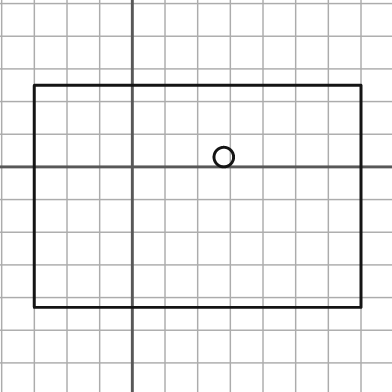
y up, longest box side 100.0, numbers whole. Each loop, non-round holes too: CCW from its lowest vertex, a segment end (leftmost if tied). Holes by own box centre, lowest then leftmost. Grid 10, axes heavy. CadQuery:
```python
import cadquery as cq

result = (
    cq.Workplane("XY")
    .moveTo(-30.0, -43.0)
    .lineTo(70.0, -43.0)
    .lineTo(70.0, 25.0)
    .lineTo(-30.0, 25.0)
    .close()
    .moveTo(28.0, 3.0)
    .circle(3.0)
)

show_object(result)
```